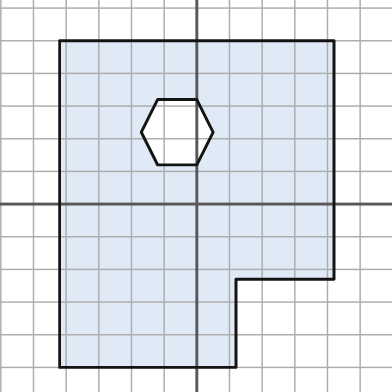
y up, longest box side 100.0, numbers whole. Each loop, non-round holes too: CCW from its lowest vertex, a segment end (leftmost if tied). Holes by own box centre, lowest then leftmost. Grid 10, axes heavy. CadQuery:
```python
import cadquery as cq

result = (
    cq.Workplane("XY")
    .moveTo(-42.0, -50.0)
    .lineTo(12.0, -50.0)
    .lineTo(12.0, -23.0)
    .lineTo(42.0, -23.0)
    .lineTo(42.0, 50.0)
    .lineTo(-42.0, 50.0)
    .close()
    .moveTo(-12.0, 12.0)
    .lineTo(0.0, 12.0)
    .lineTo(5.0, 22.0)
    .lineTo(0.0, 32.0)
    .lineTo(-12.0, 32.0)
    .lineTo(-17.0, 22.0)
    .close()
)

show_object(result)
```